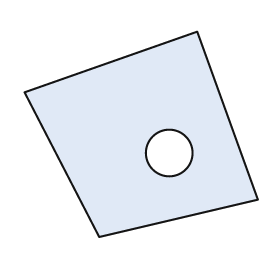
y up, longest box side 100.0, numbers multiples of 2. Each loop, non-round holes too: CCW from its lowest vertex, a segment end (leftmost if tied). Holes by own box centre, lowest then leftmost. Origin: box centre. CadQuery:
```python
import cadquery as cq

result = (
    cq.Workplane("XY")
    .moveTo(-18.0, -44.0)
    .lineTo(50.0, -28.0)
    .lineTo(24.0, 44.0)
    .lineTo(-50.0, 18.0)
    .close()
    .moveTo(12.0, -8.0)
    .circle(10.0)
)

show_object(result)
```